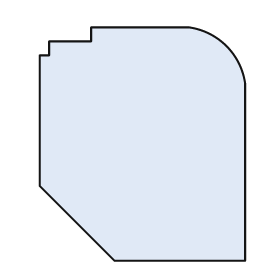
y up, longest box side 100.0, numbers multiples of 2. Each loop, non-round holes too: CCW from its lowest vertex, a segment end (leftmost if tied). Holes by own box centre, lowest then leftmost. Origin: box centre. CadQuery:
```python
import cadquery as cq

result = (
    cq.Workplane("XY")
    .moveTo(-12.0, -50.0)
    .lineTo(44.0, -50.0)
    .lineTo(44.0, 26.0)
    .threePointArc((36.0, 42.0), (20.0, 50.0))
    .lineTo(-22.0, 50.0)
    .lineTo(-22.0, 44.0)
    .lineTo(-40.0, 44.0)
    .lineTo(-40.0, 38.0)
    .lineTo(-44.0, 38.0)
    .lineTo(-44.0, -18.0)
    .close()
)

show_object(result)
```